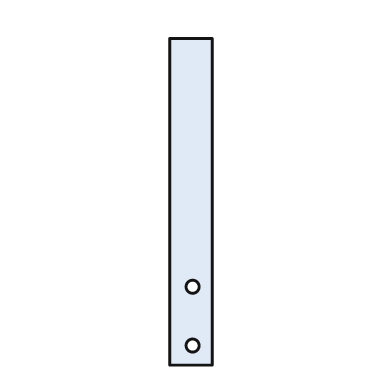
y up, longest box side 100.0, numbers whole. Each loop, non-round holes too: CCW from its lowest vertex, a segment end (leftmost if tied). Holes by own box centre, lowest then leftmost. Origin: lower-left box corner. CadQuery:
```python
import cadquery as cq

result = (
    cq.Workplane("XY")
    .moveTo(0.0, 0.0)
    .lineTo(13.0, 0.0)
    .lineTo(13.0, 100.0)
    .lineTo(0.0, 100.0)
    .close()
    .moveTo(7.0, 6.0)
    .circle(2.0)
    .moveTo(7.0, 24.0)
    .circle(2.0)
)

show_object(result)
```